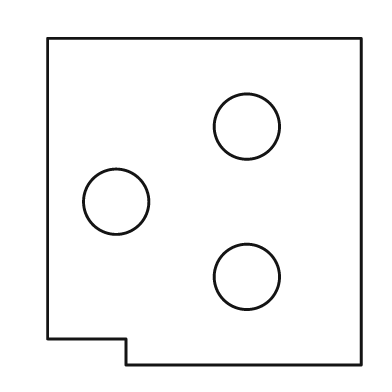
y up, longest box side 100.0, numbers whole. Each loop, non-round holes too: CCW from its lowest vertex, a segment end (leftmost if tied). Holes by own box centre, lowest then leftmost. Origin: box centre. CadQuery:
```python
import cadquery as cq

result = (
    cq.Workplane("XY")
    .moveTo(-24.0, -50.0)
    .lineTo(48.0, -50.0)
    .lineTo(48.0, 50.0)
    .lineTo(-48.0, 50.0)
    .lineTo(-48.0, -42.0)
    .lineTo(-24.0, -42.0)
    .close()
    .moveTo(13.0, -23.0)
    .circle(10.0)
    .moveTo(-27.0, 0.0)
    .circle(10.0)
    .moveTo(13.0, 23.0)
    .circle(10.0)
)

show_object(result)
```